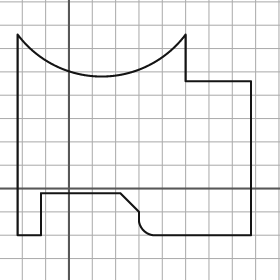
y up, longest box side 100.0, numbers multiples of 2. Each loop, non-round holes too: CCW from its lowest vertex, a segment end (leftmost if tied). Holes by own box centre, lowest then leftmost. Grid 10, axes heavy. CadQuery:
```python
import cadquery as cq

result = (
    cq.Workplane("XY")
    .moveTo(-22.0, -20.0)
    .lineTo(-12.0, -20.0)
    .lineTo(-12.0, -2.0)
    .lineTo(22.0, -2.0)
    .lineTo(30.0, -10.0)
    .lineTo(30.0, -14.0)
    .threePointArc((32.0, -18.0), (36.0, -20.0))
    .lineTo(78.0, -20.0)
    .lineTo(78.0, 46.0)
    .lineTo(50.0, 46.0)
    .lineTo(50.0, 66.0)
    .threePointArc((14.0, 48.0), (-22.0, 66.0))
    .close()
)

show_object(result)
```